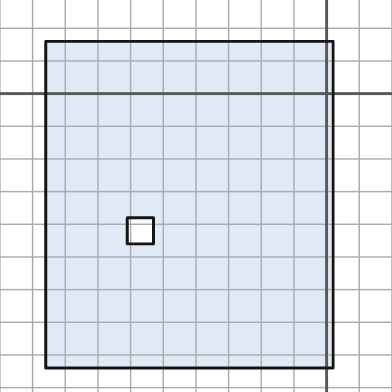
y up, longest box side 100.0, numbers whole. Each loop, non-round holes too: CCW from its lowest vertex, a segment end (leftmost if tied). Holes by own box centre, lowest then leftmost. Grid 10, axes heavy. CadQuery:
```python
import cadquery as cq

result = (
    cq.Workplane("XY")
    .moveTo(-86.0, -84.0)
    .lineTo(2.0, -84.0)
    .lineTo(2.0, 16.0)
    .lineTo(-86.0, 16.0)
    .close()
    .moveTo(-61.0, -46.0)
    .lineTo(-53.0, -46.0)
    .lineTo(-53.0, -38.0)
    .lineTo(-61.0, -38.0)
    .close()
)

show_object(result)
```